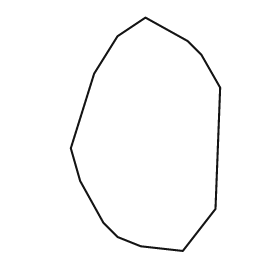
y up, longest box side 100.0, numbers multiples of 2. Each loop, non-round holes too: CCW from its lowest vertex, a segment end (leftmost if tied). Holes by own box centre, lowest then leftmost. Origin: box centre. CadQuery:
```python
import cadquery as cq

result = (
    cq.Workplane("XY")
    .moveTo(16.0, -50.0)
    .lineTo(30.0, -32.0)
    .lineTo(32.0, 20.0)
    .lineTo(24.0, 34.0)
    .lineTo(18.0, 40.0)
    .lineTo(0.0, 50.0)
    .lineTo(-12.0, 42.0)
    .lineTo(-22.0, 26.0)
    .lineTo(-32.0, -6.0)
    .lineTo(-28.0, -20.0)
    .lineTo(-18.0, -38.0)
    .lineTo(-12.0, -44.0)
    .lineTo(-2.0, -48.0)
    .close()
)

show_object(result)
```